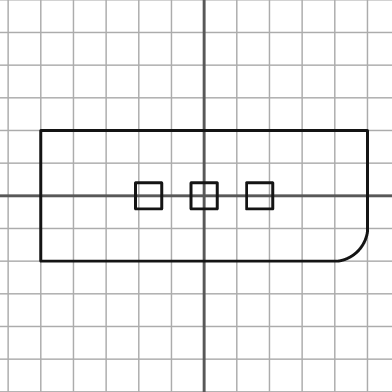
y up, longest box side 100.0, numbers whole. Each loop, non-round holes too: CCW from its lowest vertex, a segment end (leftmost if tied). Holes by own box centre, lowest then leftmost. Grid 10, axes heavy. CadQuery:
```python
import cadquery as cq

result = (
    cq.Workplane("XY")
    .moveTo(-50.0, -20.0)
    .lineTo(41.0, -20.0)
    .threePointArc((47.0, -17.0), (50.0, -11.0))
    .lineTo(50.0, 20.0)
    .lineTo(-50.0, 20.0)
    .close()
    .moveTo(-21.0, -4.0)
    .lineTo(-13.0, -4.0)
    .lineTo(-13.0, 4.0)
    .lineTo(-21.0, 4.0)
    .close()
    .moveTo(-4.0, -4.0)
    .lineTo(4.0, -4.0)
    .lineTo(4.0, 4.0)
    .lineTo(-4.0, 4.0)
    .close()
    .moveTo(13.0, -4.0)
    .lineTo(21.0, -4.0)
    .lineTo(21.0, 4.0)
    .lineTo(13.0, 4.0)
    .close()
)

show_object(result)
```